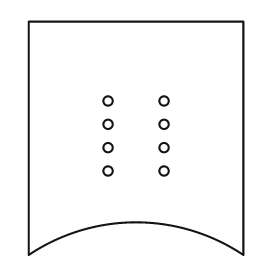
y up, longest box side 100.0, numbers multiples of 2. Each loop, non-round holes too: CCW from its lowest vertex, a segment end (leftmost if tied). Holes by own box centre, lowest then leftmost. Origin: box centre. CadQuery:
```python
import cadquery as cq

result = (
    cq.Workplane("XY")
    .moveTo(-46.0, -50.0)
    .threePointArc((0.0, -36.0), (46.0, -50.0))
    .lineTo(46.0, 50.0)
    .lineTo(-46.0, 50.0)
    .close()
    .moveTo(-12.0, -14.0)
    .circle(2.0)
    .moveTo(12.0, -14.0)
    .circle(2.0)
    .moveTo(-12.0, -4.0)
    .circle(2.0)
    .moveTo(12.0, -4.0)
    .circle(2.0)
    .moveTo(-12.0, 6.0)
    .circle(2.0)
    .moveTo(12.0, 6.0)
    .circle(2.0)
    .moveTo(-12.0, 16.0)
    .circle(2.0)
    .moveTo(12.0, 16.0)
    .circle(2.0)
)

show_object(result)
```